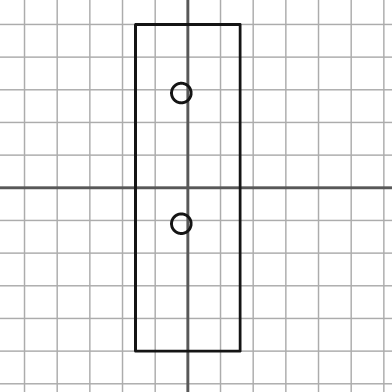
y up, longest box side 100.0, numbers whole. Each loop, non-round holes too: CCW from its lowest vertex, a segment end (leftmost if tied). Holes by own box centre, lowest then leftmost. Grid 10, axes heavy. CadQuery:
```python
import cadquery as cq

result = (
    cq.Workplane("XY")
    .moveTo(-16.0, -50.0)
    .lineTo(16.0, -50.0)
    .lineTo(16.0, 50.0)
    .lineTo(-16.0, 50.0)
    .close()
    .moveTo(-2.0, -11.0)
    .circle(3.0)
    .moveTo(-2.0, 29.0)
    .circle(3.0)
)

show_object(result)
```